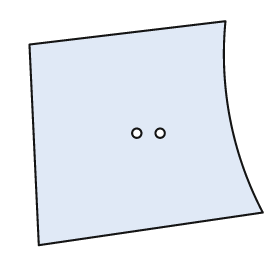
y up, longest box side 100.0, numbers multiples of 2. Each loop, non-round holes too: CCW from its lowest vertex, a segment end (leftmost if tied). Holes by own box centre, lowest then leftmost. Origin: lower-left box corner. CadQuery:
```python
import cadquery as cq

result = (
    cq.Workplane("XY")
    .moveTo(4.0, 0.0)
    .lineTo(100.0, 14.0)
    .threePointArc((86.0, 54.0), (84.0, 96.0))
    .lineTo(0.0, 86.0)
    .close()
    .moveTo(46.0, 48.0)
    .circle(2.0)
    .moveTo(56.0, 48.0)
    .circle(2.0)
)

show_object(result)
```